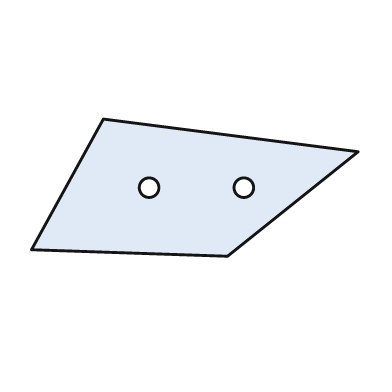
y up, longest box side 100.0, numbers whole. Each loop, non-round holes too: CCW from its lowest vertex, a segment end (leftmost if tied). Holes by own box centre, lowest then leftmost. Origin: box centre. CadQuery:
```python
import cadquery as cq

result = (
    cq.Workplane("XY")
    .moveTo(10.0, -21.0)
    .lineTo(50.0, 11.0)
    .lineTo(-28.0, 21.0)
    .lineTo(-50.0, -19.0)
    .close()
    .moveTo(-14.0, 0.0)
    .circle(3.0)
    .moveTo(15.0, 0.0)
    .circle(3.0)
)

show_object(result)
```